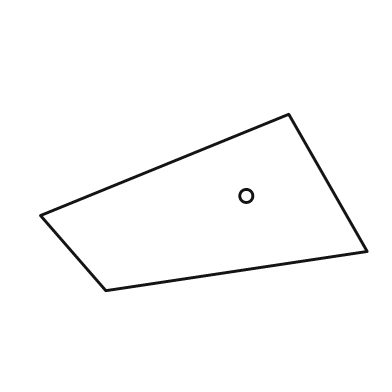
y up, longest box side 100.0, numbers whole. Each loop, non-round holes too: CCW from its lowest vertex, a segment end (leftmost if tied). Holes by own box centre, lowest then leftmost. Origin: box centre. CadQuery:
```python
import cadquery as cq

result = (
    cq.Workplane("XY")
    .moveTo(-30.0, -27.0)
    .lineTo(50.0, -15.0)
    .lineTo(26.0, 27.0)
    .lineTo(-50.0, -4.0)
    .close()
    .moveTo(13.0, 2.0)
    .circle(2.0)
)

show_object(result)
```